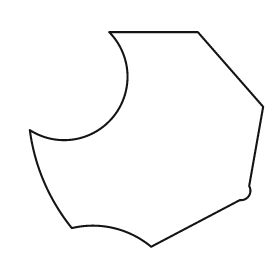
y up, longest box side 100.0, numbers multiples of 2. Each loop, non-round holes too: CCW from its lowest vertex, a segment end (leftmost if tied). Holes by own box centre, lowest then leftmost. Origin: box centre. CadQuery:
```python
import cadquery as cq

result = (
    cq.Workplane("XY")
    .moveTo(2.0, -46.0)
    .lineTo(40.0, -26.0)
    .threePointArc((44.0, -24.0), (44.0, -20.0))
    .lineTo(50.0, 14.0)
    .lineTo(22.0, 46.0)
    .lineTo(-16.0, 46.0)
    .threePointArc((-14.0, 10.0), (-50.0, 4.0))
    .threePointArc((-44.0, -18.0), (-32.0, -38.0))
    .threePointArc((-14.0, -38.0), (2.0, -46.0))
    .close()
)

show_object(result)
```